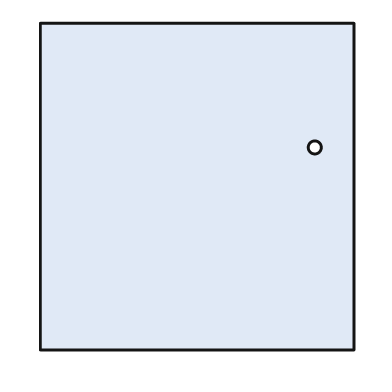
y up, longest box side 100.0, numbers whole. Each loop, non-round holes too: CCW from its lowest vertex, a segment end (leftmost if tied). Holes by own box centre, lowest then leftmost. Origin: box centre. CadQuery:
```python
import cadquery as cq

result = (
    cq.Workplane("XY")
    .moveTo(-48.0, -50.0)
    .lineTo(48.0, -50.0)
    .lineTo(48.0, 50.0)
    .lineTo(-48.0, 50.0)
    .close()
    .moveTo(36.0, 12.0)
    .circle(2.0)
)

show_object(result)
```